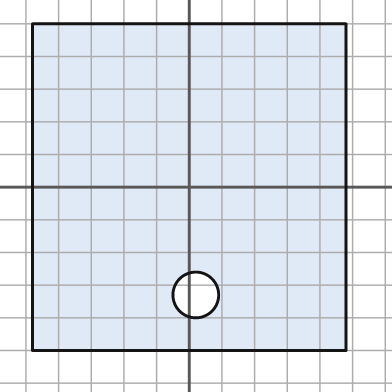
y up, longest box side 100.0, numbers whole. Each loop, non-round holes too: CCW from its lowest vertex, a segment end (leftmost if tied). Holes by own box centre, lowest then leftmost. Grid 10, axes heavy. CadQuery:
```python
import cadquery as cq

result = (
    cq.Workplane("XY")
    .moveTo(-48.0, -50.0)
    .lineTo(48.0, -50.0)
    .lineTo(48.0, 50.0)
    .lineTo(-48.0, 50.0)
    .close()
    .moveTo(2.0, -33.0)
    .circle(7.0)
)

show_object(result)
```